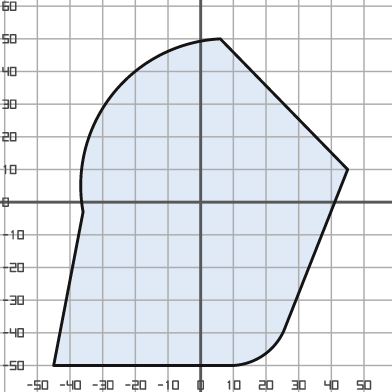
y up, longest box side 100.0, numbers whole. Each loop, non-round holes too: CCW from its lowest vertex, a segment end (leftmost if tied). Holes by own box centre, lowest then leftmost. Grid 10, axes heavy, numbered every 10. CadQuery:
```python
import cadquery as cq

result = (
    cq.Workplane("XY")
    .moveTo(-45.0, -50.0)
    .lineTo(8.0, -50.0)
    .threePointArc((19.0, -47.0), (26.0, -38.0))
    .lineTo(45.0, 10.0)
    .lineTo(6.0, 50.0)
    .threePointArc((-27.0, 33.0), (-36.0, -3.0))
    .close()
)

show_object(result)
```